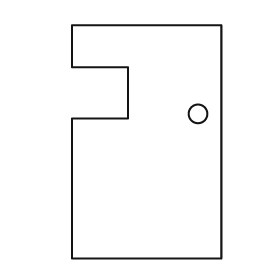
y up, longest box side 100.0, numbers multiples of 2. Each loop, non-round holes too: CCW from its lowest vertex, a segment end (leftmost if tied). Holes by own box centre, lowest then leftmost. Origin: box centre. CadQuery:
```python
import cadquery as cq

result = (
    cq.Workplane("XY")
    .moveTo(-32.0, -50.0)
    .lineTo(32.0, -50.0)
    .lineTo(32.0, 50.0)
    .lineTo(-32.0, 50.0)
    .lineTo(-32.0, 32.0)
    .lineTo(-8.0, 32.0)
    .lineTo(-8.0, 10.0)
    .lineTo(-32.0, 10.0)
    .close()
    .moveTo(22.0, 12.0)
    .circle(4.0)
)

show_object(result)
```